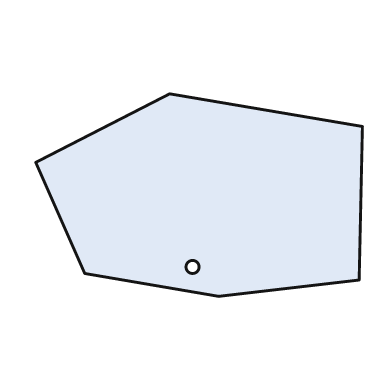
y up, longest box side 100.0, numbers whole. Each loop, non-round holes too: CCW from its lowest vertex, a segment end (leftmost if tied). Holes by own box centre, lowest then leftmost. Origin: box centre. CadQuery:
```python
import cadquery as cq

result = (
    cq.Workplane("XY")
    .moveTo(6.0, -31.0)
    .lineTo(49.0, -26.0)
    .lineTo(50.0, 21.0)
    .lineTo(-9.0, 31.0)
    .lineTo(-50.0, 10.0)
    .lineTo(-35.0, -24.0)
    .close()
    .moveTo(-2.0, -22.0)
    .circle(2.0)
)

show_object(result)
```